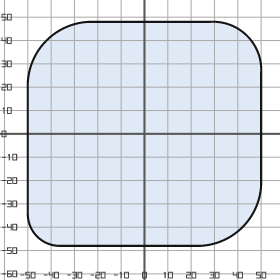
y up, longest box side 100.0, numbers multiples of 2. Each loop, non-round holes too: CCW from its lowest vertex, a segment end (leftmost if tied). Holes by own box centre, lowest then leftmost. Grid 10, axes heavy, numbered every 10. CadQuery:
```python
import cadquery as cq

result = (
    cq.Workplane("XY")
    .moveTo(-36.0, -48.0)
    .lineTo(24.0, -48.0)
    .threePointArc((42.0, -40.0), (50.0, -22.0))
    .lineTo(50.0, 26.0)
    .threePointArc((44.0, 42.0), (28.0, 48.0))
    .lineTo(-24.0, 48.0)
    .threePointArc((-42.0, 40.0), (-50.0, 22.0))
    .lineTo(-50.0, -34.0)
    .threePointArc((-46.0, -44.0), (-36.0, -48.0))
    .close()
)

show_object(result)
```